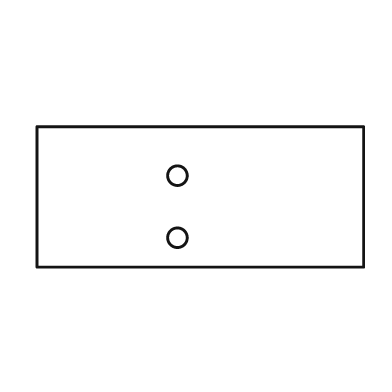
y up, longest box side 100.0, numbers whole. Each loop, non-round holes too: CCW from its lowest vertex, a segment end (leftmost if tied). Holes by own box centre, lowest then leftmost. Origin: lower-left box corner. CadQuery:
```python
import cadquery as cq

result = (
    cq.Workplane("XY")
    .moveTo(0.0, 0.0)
    .lineTo(100.0, 0.0)
    .lineTo(100.0, 43.0)
    .lineTo(0.0, 43.0)
    .close()
    .moveTo(43.0, 9.0)
    .circle(3.0)
    .moveTo(43.0, 28.0)
    .circle(3.0)
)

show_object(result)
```